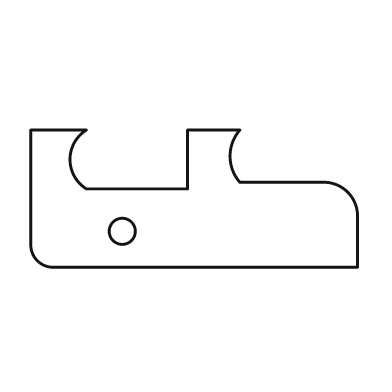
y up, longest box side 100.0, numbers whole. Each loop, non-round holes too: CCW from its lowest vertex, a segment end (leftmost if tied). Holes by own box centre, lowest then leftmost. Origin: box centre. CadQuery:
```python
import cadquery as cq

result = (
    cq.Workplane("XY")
    .moveTo(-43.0, -21.0)
    .lineTo(50.0, -21.0)
    .lineTo(50.0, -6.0)
    .threePointArc((47.0, 2.0), (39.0, 5.0))
    .lineTo(14.0, 5.0)
    .threePointArc((11.0, 13.0), (14.0, 21.0))
    .lineTo(-2.0, 21.0)
    .lineTo(-2.0, 3.0)
    .lineTo(-33.0, 3.0)
    .threePointArc((-38.0, 12.0), (-33.0, 21.0))
    .lineTo(-50.0, 21.0)
    .lineTo(-50.0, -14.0)
    .threePointArc((-48.0, -19.0), (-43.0, -21.0))
    .close()
    .moveTo(-22.0, -10.0)
    .circle(4.0)
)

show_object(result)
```